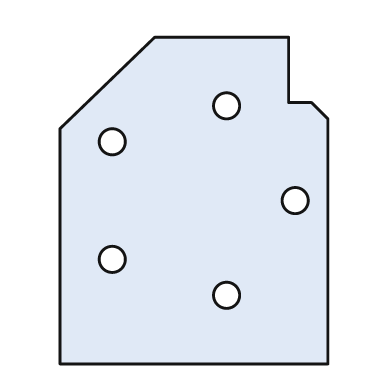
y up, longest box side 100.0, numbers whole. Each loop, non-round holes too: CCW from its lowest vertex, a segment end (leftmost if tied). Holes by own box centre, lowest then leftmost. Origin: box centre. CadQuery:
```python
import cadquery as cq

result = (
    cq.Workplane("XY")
    .moveTo(-41.0, -50.0)
    .lineTo(41.0, -50.0)
    .lineTo(41.0, 25.0)
    .lineTo(36.0, 30.0)
    .lineTo(29.0, 30.0)
    .lineTo(29.0, 50.0)
    .lineTo(-12.0, 50.0)
    .lineTo(-41.0, 22.0)
    .close()
    .moveTo(10.0, -29.0)
    .circle(4.0)
    .moveTo(-25.0, -18.0)
    .circle(4.0)
    .moveTo(31.0, 0.0)
    .circle(4.0)
    .moveTo(-25.0, 18.0)
    .circle(4.0)
    .moveTo(10.0, 29.0)
    .circle(4.0)
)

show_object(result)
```